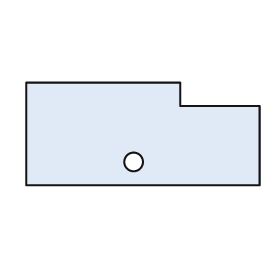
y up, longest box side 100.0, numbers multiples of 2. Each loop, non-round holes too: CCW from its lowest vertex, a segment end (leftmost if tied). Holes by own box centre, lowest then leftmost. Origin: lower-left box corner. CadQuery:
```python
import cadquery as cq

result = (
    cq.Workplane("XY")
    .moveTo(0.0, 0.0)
    .lineTo(100.0, 0.0)
    .lineTo(100.0, 34.0)
    .lineTo(66.0, 34.0)
    .lineTo(66.0, 44.0)
    .lineTo(0.0, 44.0)
    .close()
    .moveTo(46.0, 10.0)
    .circle(4.0)
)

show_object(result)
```